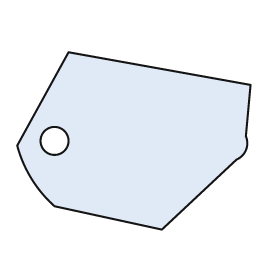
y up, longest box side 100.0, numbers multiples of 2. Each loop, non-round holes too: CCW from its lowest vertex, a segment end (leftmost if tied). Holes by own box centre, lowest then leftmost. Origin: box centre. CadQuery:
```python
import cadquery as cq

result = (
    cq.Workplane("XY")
    .moveTo(12.0, -38.0)
    .lineTo(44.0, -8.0)
    .threePointArc((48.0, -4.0), (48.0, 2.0))
    .lineTo(50.0, 24.0)
    .lineTo(-28.0, 38.0)
    .lineTo(-50.0, -2.0)
    .threePointArc((-44.0, -16.0), (-34.0, -28.0))
    .close()
    .moveTo(-34.0, 0.0)
    .circle(6.0)
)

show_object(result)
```